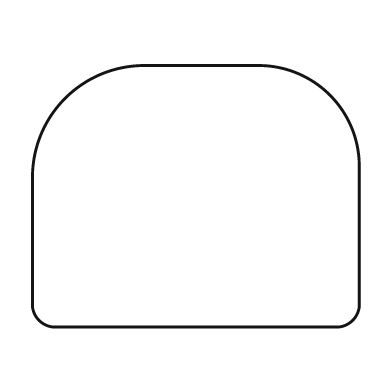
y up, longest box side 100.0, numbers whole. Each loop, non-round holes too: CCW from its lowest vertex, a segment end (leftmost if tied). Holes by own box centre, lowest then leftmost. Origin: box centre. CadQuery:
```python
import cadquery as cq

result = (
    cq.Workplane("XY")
    .moveTo(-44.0, -40.0)
    .lineTo(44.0, -40.0)
    .threePointArc((48.0, -38.0), (50.0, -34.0))
    .lineTo(50.0, 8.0)
    .threePointArc((41.0, 31.0), (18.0, 40.0))
    .lineTo(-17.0, 40.0)
    .threePointArc((-40.0, 30.0), (-50.0, 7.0))
    .lineTo(-50.0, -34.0)
    .threePointArc((-48.0, -38.0), (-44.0, -40.0))
    .close()
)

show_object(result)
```